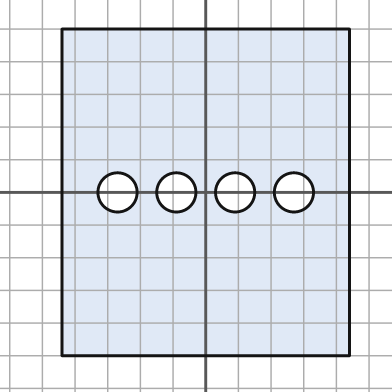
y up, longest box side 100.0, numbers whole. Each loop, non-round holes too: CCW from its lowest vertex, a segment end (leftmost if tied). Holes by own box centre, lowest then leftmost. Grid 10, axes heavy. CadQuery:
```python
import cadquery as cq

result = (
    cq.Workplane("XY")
    .moveTo(-44.0, -50.0)
    .lineTo(44.0, -50.0)
    .lineTo(44.0, 50.0)
    .lineTo(-44.0, 50.0)
    .close()
    .moveTo(-27.0, 0.0)
    .circle(6.0)
    .moveTo(-9.0, 0.0)
    .circle(6.0)
    .moveTo(9.0, 0.0)
    .circle(6.0)
    .moveTo(27.0, 0.0)
    .circle(6.0)
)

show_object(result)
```